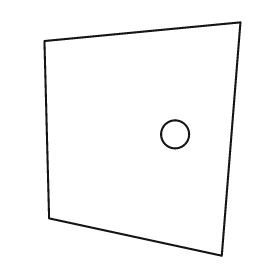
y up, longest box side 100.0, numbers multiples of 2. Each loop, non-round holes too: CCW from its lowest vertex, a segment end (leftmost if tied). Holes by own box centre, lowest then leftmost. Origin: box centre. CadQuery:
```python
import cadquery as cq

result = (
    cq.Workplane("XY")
    .moveTo(34.0, -50.0)
    .lineTo(42.0, 50.0)
    .lineTo(-42.0, 42.0)
    .lineTo(-40.0, -34.0)
    .close()
    .moveTo(14.0, 2.0)
    .circle(6.0)
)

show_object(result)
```